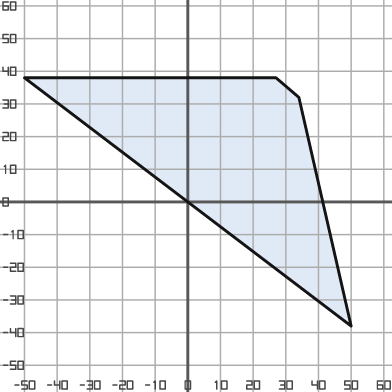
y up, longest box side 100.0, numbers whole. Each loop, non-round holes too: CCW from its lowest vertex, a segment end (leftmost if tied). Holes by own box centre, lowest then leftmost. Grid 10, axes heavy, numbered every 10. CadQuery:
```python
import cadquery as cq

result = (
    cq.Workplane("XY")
    .moveTo(50.0, -38.0)
    .lineTo(34.0, 32.0)
    .lineTo(27.0, 38.0)
    .lineTo(-50.0, 38.0)
    .close()
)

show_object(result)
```